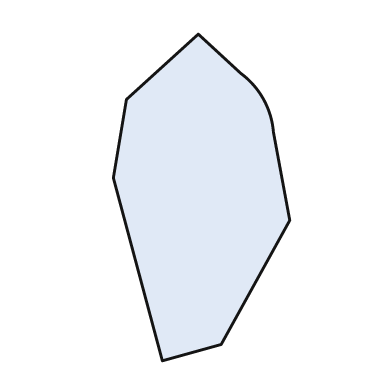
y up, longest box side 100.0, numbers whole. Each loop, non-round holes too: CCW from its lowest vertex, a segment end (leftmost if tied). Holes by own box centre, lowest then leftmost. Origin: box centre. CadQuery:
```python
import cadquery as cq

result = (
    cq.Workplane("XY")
    .moveTo(-12.0, -50.0)
    .lineTo(6.0, -45.0)
    .lineTo(27.0, -7.0)
    .lineTo(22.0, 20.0)
    .threePointArc((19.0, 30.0), (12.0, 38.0))
    .lineTo(-1.0, 50.0)
    .lineTo(-23.0, 30.0)
    .lineTo(-27.0, 6.0)
    .close()
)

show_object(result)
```